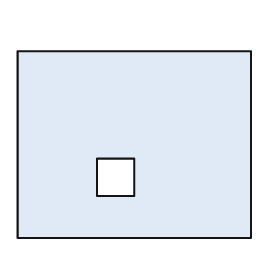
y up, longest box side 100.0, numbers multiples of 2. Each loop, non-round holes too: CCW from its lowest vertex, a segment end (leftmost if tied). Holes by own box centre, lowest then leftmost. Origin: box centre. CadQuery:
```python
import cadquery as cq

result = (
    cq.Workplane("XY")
    .moveTo(-50.0, -40.0)
    .lineTo(50.0, -40.0)
    .lineTo(50.0, 40.0)
    .lineTo(-50.0, 40.0)
    .close()
    .moveTo(-16.0, -22.0)
    .lineTo(0.0, -22.0)
    .lineTo(0.0, -6.0)
    .lineTo(-16.0, -6.0)
    .close()
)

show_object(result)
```